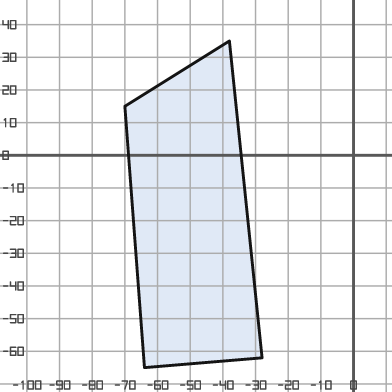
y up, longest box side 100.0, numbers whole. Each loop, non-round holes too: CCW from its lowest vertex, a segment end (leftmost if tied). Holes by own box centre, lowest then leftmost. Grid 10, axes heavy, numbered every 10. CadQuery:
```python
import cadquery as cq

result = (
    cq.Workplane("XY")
    .moveTo(-64.0, -65.0)
    .lineTo(-28.0, -62.0)
    .lineTo(-38.0, 35.0)
    .lineTo(-70.0, 15.0)
    .close()
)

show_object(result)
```